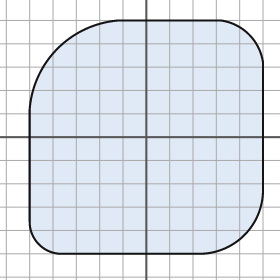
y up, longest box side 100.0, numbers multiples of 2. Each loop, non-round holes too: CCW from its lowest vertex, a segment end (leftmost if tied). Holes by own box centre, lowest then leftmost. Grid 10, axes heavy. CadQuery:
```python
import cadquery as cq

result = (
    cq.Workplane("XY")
    .moveTo(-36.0, -50.0)
    .lineTo(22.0, -50.0)
    .threePointArc((42.0, -42.0), (50.0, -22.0))
    .lineTo(50.0, 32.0)
    .threePointArc((44.0, 44.0), (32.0, 50.0))
    .lineTo(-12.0, 50.0)
    .threePointArc((-38.0, 38.0), (-50.0, 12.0))
    .lineTo(-50.0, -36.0)
    .threePointArc((-46.0, -46.0), (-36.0, -50.0))
    .close()
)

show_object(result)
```